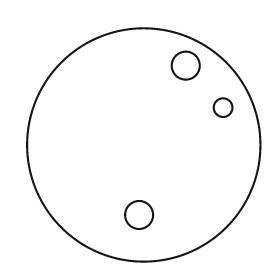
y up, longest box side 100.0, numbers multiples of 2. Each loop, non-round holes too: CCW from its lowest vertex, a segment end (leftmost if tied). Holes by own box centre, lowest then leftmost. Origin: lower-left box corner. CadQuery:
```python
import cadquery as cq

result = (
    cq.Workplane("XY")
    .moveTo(50.0, 50.0)
    .circle(50.0)
    .moveTo(48.0, 20.0)
    .circle(6.0)
    .moveTo(84.0, 66.0)
    .circle(4.0)
    .moveTo(68.0, 84.0)
    .circle(6.0)
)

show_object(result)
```